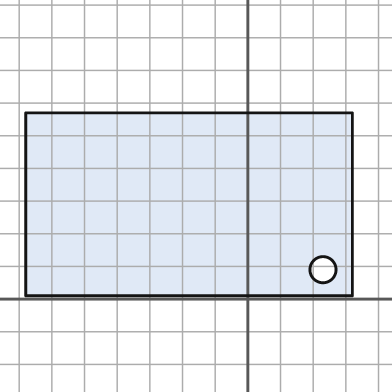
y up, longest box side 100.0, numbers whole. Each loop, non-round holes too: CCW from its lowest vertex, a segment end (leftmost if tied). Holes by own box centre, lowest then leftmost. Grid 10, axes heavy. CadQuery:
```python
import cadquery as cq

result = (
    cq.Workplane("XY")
    .moveTo(-68.0, 1.0)
    .lineTo(32.0, 1.0)
    .lineTo(32.0, 57.0)
    .lineTo(-68.0, 57.0)
    .close()
    .moveTo(23.0, 9.0)
    .circle(4.0)
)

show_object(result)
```